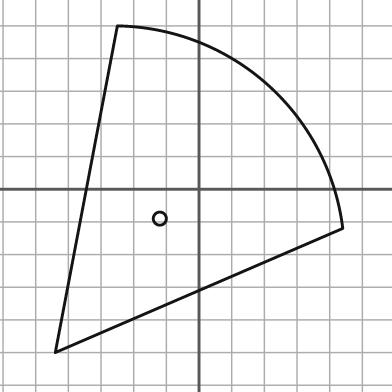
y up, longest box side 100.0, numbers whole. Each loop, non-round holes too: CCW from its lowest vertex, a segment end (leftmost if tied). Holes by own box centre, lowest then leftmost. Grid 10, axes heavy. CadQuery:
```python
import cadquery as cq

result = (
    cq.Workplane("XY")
    .moveTo(-44.0, -50.0)
    .lineTo(44.0, -12.0)
    .threePointArc((21.0, 32.0), (-25.0, 50.0))
    .close()
    .moveTo(-12.0, -9.0)
    .circle(2.0)
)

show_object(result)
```